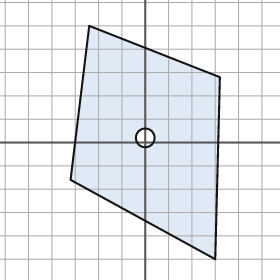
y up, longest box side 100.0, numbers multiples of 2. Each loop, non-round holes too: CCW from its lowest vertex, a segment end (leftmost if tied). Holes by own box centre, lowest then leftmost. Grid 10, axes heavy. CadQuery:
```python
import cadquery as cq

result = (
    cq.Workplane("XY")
    .moveTo(30.0, -50.0)
    .lineTo(32.0, 28.0)
    .lineTo(-24.0, 50.0)
    .lineTo(-32.0, -16.0)
    .close()
    .moveTo(0.0, 2.0)
    .circle(4.0)
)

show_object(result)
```